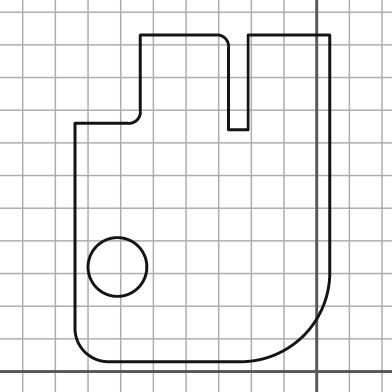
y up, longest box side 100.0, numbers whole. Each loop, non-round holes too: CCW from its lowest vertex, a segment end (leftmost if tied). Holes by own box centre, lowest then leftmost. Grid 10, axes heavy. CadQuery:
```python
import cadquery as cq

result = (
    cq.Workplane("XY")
    .moveTo(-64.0, 3.0)
    .lineTo(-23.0, 3.0)
    .threePointArc((-4.0, 11.0), (4.0, 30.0))
    .lineTo(4.0, 103.0)
    .lineTo(-21.0, 103.0)
    .lineTo(-21.0, 74.0)
    .lineTo(-27.0, 74.0)
    .lineTo(-27.0, 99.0)
    .threePointArc((-28.0, 102.0), (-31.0, 103.0))
    .lineTo(-54.0, 103.0)
    .lineTo(-54.0, 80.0)
    .threePointArc((-55.0, 77.0), (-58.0, 76.0))
    .lineTo(-74.0, 76.0)
    .lineTo(-74.0, 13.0)
    .threePointArc((-71.0, 6.0), (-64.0, 3.0))
    .close()
    .moveTo(-61.0, 32.0)
    .circle(9.0)
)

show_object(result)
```